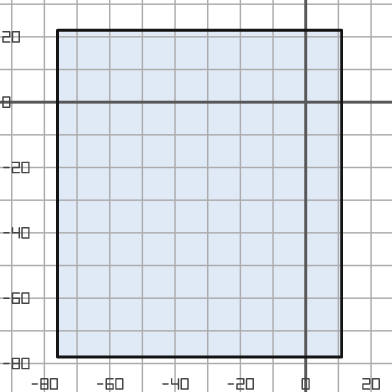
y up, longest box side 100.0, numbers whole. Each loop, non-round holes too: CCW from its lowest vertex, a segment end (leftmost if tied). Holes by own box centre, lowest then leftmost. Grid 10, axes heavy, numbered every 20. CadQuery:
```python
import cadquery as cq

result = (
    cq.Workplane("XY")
    .moveTo(-76.0, -78.0)
    .lineTo(11.0, -78.0)
    .lineTo(11.0, 22.0)
    .lineTo(-76.0, 22.0)
    .close()
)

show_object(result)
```